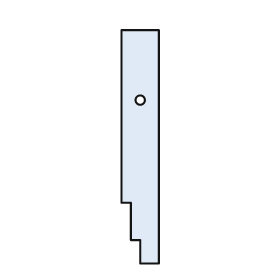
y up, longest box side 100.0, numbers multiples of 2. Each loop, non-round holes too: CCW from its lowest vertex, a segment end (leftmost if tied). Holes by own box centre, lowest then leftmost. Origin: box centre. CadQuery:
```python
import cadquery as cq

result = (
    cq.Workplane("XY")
    .moveTo(0.0, -50.0)
    .lineTo(8.0, -50.0)
    .lineTo(8.0, 50.0)
    .lineTo(-8.0, 50.0)
    .lineTo(-8.0, -24.0)
    .lineTo(-4.0, -24.0)
    .lineTo(-4.0, -40.0)
    .lineTo(0.0, -40.0)
    .close()
    .moveTo(0.0, 20.0)
    .circle(2.0)
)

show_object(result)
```